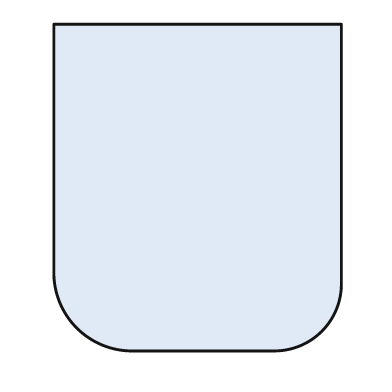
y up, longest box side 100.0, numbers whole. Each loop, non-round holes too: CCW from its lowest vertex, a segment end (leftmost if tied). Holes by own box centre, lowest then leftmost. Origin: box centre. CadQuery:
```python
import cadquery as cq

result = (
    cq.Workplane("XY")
    .moveTo(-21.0, -50.0)
    .lineTo(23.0, -50.0)
    .threePointArc((38.0, -44.0), (44.0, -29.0))
    .lineTo(44.0, 50.0)
    .lineTo(-44.0, 50.0)
    .lineTo(-44.0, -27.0)
    .threePointArc((-37.0, -43.0), (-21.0, -50.0))
    .close()
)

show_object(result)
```